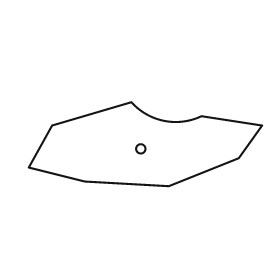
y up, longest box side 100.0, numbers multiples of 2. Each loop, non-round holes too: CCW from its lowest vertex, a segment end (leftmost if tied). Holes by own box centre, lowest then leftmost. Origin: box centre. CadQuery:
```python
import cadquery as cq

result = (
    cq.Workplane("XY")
    .moveTo(10.0, -18.0)
    .lineTo(40.0, -6.0)
    .lineTo(50.0, 8.0)
    .lineTo(24.0, 12.0)
    .threePointArc((8.0, 10.0), (-6.0, 18.0))
    .lineTo(-40.0, 8.0)
    .lineTo(-50.0, -10.0)
    .lineTo(-26.0, -16.0)
    .close()
    .moveTo(-2.0, -2.0)
    .circle(2.0)
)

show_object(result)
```